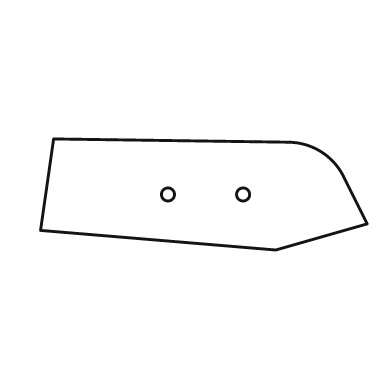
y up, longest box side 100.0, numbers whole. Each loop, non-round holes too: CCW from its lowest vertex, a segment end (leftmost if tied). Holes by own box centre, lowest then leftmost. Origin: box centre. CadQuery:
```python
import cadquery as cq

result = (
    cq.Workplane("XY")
    .moveTo(22.0, -17.0)
    .lineTo(50.0, -9.0)
    .lineTo(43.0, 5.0)
    .threePointArc((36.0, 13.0), (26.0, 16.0))
    .lineTo(-46.0, 17.0)
    .lineTo(-50.0, -11.0)
    .close()
    .moveTo(-11.0, 0.0)
    .circle(2.0)
    .moveTo(12.0, 0.0)
    .circle(2.0)
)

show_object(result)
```